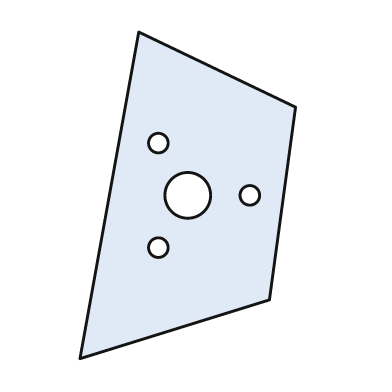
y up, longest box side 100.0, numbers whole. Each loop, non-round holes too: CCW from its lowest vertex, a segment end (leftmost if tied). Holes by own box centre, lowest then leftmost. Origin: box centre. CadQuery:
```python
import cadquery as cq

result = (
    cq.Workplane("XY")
    .moveTo(-33.0, -50.0)
    .lineTo(25.0, -32.0)
    .lineTo(33.0, 27.0)
    .lineTo(-15.0, 50.0)
    .close()
    .moveTo(-9.0, -16.0)
    .circle(3.0)
    .moveTo(0.0, 0.0)
    .circle(7.0)
    .moveTo(19.0, 0.0)
    .circle(3.0)
    .moveTo(-9.0, 16.0)
    .circle(3.0)
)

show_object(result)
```